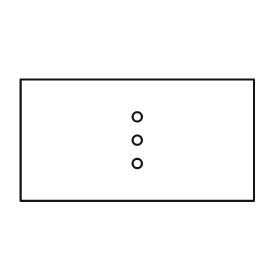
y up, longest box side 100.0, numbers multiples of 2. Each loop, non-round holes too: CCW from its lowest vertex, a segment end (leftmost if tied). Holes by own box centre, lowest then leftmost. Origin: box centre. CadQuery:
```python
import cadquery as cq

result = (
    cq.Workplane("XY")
    .moveTo(-50.0, -26.0)
    .lineTo(50.0, -26.0)
    .lineTo(50.0, 26.0)
    .lineTo(-50.0, 26.0)
    .close()
    .moveTo(0.0, -10.0)
    .circle(2.0)
    .moveTo(0.0, 0.0)
    .circle(2.0)
    .moveTo(0.0, 10.0)
    .circle(2.0)
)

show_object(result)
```